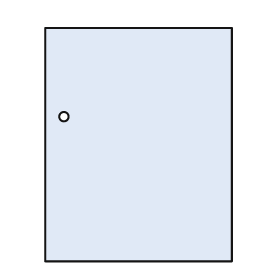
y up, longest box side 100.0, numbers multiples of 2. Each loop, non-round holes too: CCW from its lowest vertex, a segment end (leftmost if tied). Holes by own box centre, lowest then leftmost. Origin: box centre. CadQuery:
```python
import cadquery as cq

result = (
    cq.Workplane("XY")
    .moveTo(-40.0, -50.0)
    .lineTo(40.0, -50.0)
    .lineTo(40.0, 50.0)
    .lineTo(-40.0, 50.0)
    .close()
    .moveTo(-32.0, 12.0)
    .circle(2.0)
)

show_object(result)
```